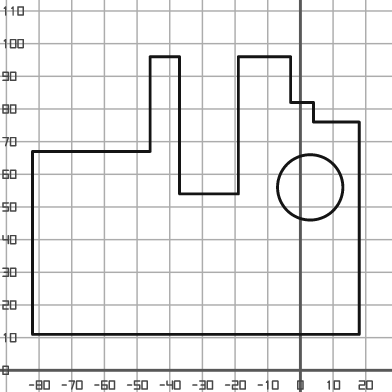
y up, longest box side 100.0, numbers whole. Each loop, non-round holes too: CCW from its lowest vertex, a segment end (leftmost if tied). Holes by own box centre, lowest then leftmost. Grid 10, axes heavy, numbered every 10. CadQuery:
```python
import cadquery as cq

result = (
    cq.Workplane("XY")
    .moveTo(-82.0, 11.0)
    .lineTo(18.0, 11.0)
    .lineTo(18.0, 76.0)
    .lineTo(4.0, 76.0)
    .lineTo(4.0, 82.0)
    .lineTo(-3.0, 82.0)
    .lineTo(-3.0, 96.0)
    .lineTo(-19.0, 96.0)
    .lineTo(-19.0, 54.0)
    .lineTo(-37.0, 54.0)
    .lineTo(-37.0, 96.0)
    .lineTo(-46.0, 96.0)
    .lineTo(-46.0, 67.0)
    .lineTo(-82.0, 67.0)
    .close()
    .moveTo(3.0, 56.0)
    .circle(10.0)
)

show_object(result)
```